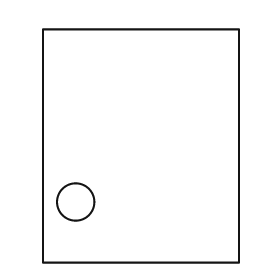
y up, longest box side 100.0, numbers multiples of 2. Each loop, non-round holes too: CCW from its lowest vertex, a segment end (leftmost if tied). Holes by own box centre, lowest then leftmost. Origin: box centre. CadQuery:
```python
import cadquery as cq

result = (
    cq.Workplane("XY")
    .moveTo(-42.0, -50.0)
    .lineTo(42.0, -50.0)
    .lineTo(42.0, 50.0)
    .lineTo(-42.0, 50.0)
    .close()
    .moveTo(-28.0, -24.0)
    .circle(8.0)
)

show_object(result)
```